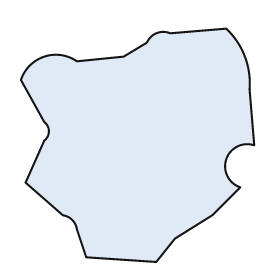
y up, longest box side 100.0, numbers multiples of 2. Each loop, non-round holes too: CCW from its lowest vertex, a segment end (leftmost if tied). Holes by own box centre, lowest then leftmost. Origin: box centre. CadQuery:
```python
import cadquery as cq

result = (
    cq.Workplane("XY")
    .moveTo(8.0, -50.0)
    .lineTo(16.0, -40.0)
    .lineTo(32.0, -30.0)
    .lineTo(44.0, -18.0)
    .threePointArc((38.0, -6.0), (50.0, 0.0))
    .lineTo(48.0, 24.0)
    .threePointArc((46.0, 38.0), (38.0, 50.0))
    .lineTo(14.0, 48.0)
    .threePointArc((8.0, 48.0), (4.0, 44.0))
    .lineTo(-6.0, 38.0)
    .lineTo(-26.0, 36.0)
    .threePointArc((-40.0, 38.0), (-50.0, 28.0))
    .lineTo(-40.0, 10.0)
    .threePointArc((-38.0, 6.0), (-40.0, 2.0))
    .lineTo(-48.0, -16.0)
    .lineTo(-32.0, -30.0)
    .threePointArc((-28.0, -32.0), (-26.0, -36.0))
    .lineTo(-22.0, -48.0)
    .close()
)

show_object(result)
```